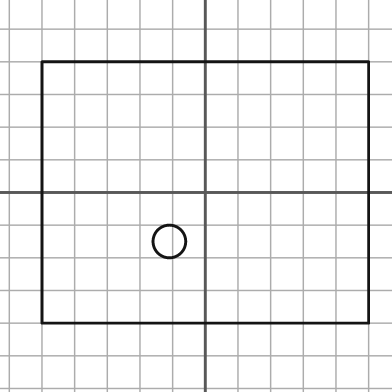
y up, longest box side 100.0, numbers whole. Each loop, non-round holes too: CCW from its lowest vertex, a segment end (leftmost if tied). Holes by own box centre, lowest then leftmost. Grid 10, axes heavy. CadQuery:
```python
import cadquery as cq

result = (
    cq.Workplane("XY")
    .moveTo(-50.0, -40.0)
    .lineTo(50.0, -40.0)
    .lineTo(50.0, 40.0)
    .lineTo(-50.0, 40.0)
    .close()
    .moveTo(-11.0, -15.0)
    .circle(5.0)
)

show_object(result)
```